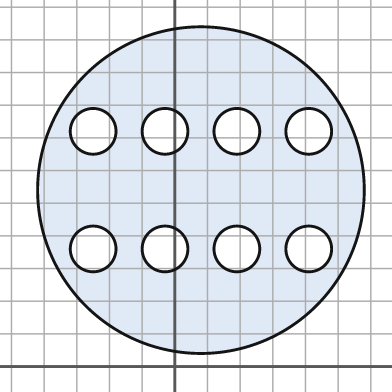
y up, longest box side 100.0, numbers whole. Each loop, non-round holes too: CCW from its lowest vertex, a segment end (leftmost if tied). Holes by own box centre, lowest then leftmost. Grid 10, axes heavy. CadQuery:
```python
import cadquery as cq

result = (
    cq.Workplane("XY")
    .moveTo(8.0, 54.0)
    .circle(50.0)
    .moveTo(-25.0, 36.0)
    .circle(7.0)
    .moveTo(-3.0, 36.0)
    .circle(7.0)
    .moveTo(19.0, 36.0)
    .circle(7.0)
    .moveTo(41.0, 36.0)
    .circle(7.0)
    .moveTo(-25.0, 72.0)
    .circle(7.0)
    .moveTo(-3.0, 72.0)
    .circle(7.0)
    .moveTo(19.0, 72.0)
    .circle(7.0)
    .moveTo(41.0, 72.0)
    .circle(7.0)
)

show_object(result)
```